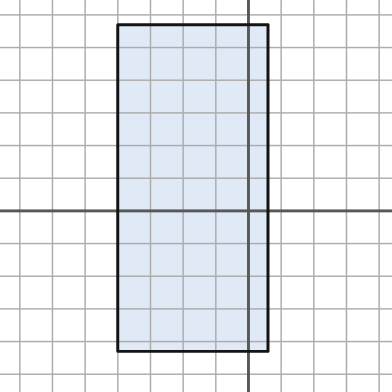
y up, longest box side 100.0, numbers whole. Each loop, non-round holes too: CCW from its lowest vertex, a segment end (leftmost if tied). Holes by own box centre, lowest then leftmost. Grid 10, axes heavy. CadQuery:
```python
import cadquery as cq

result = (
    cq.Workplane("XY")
    .moveTo(-40.0, -43.0)
    .lineTo(6.0, -43.0)
    .lineTo(6.0, 57.0)
    .lineTo(-40.0, 57.0)
    .close()
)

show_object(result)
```